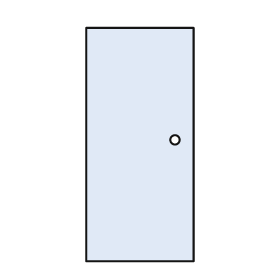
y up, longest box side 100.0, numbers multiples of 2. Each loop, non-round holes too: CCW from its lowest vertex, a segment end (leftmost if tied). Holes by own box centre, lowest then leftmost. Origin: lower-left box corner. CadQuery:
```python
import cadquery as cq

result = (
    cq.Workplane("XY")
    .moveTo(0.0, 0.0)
    .lineTo(46.0, 0.0)
    .lineTo(46.0, 100.0)
    .lineTo(0.0, 100.0)
    .close()
    .moveTo(38.0, 52.0)
    .circle(2.0)
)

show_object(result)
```